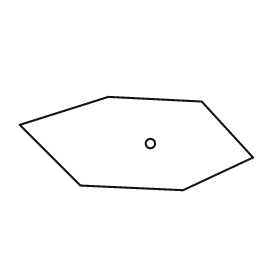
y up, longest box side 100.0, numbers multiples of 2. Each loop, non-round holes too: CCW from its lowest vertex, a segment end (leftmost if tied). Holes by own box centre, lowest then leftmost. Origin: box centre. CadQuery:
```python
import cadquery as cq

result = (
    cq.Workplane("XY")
    .moveTo(20.0, -20.0)
    .lineTo(50.0, -6.0)
    .lineTo(28.0, 18.0)
    .lineTo(-12.0, 20.0)
    .lineTo(-50.0, 8.0)
    .lineTo(-24.0, -18.0)
    .close()
    .moveTo(6.0, 0.0)
    .circle(2.0)
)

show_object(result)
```